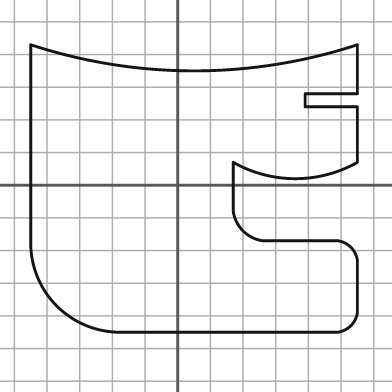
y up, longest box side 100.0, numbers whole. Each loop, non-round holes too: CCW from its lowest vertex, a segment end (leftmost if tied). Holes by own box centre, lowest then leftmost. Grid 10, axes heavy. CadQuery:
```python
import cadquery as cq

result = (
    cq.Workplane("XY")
    .moveTo(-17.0, -45.0)
    .lineTo(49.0, -45.0)
    .threePointArc((53.0, -43.0), (55.0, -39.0))
    .lineTo(55.0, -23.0)
    .threePointArc((53.0, -19.0), (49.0, -17.0))
    .lineTo(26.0, -17.0)
    .threePointArc((20.0, -14.0), (17.0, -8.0))
    .lineTo(17.0, 7.0)
    .threePointArc((36.0, 2.0), (55.0, 7.0))
    .lineTo(55.0, 24.0)
    .lineTo(39.0, 24.0)
    .lineTo(39.0, 28.0)
    .lineTo(55.0, 28.0)
    .lineTo(55.0, 43.0)
    .threePointArc((5.0, 35.0), (-45.0, 43.0))
    .lineTo(-45.0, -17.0)
    .threePointArc((-37.0, -37.0), (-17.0, -45.0))
    .close()
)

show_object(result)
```